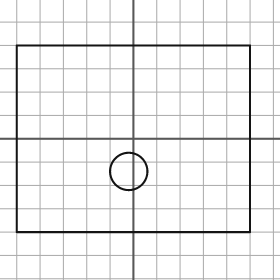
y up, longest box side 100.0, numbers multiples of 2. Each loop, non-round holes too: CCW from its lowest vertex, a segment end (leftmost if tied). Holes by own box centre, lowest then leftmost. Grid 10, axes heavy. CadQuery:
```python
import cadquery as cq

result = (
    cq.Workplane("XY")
    .moveTo(-50.0, -40.0)
    .lineTo(50.0, -40.0)
    .lineTo(50.0, 40.0)
    .lineTo(-50.0, 40.0)
    .close()
    .moveTo(-2.0, -14.0)
    .circle(8.0)
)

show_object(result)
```